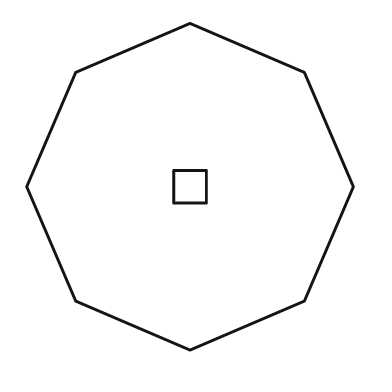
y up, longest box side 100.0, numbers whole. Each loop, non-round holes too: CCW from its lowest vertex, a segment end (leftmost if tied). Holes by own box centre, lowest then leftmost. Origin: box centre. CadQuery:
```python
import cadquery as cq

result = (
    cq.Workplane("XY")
    .moveTo(0.0, -50.0)
    .lineTo(35.0, -35.0)
    .lineTo(50.0, 0.0)
    .lineTo(35.0, 35.0)
    .lineTo(0.0, 50.0)
    .lineTo(-35.0, 35.0)
    .lineTo(-50.0, 0.0)
    .lineTo(-35.0, -35.0)
    .close()
    .moveTo(-5.0, -5.0)
    .lineTo(5.0, -5.0)
    .lineTo(5.0, 5.0)
    .lineTo(-5.0, 5.0)
    .close()
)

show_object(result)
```